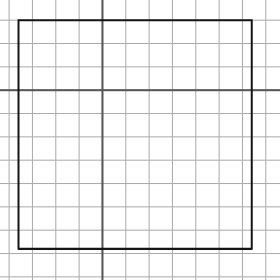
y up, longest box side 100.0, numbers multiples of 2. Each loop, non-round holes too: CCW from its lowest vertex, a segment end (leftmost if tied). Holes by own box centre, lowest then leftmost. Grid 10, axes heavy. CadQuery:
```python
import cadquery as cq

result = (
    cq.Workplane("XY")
    .moveTo(-36.0, -68.0)
    .lineTo(64.0, -68.0)
    .lineTo(64.0, 30.0)
    .lineTo(-36.0, 30.0)
    .close()
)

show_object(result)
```